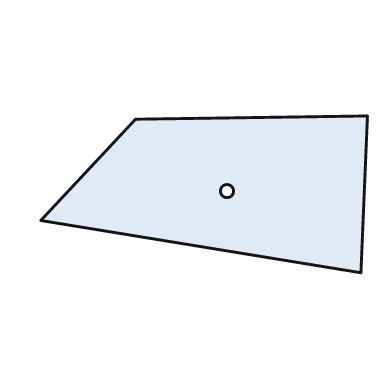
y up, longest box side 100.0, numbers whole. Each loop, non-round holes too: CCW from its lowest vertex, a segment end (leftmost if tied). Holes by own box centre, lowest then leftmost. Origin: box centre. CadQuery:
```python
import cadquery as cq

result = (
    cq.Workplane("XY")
    .moveTo(48.0, -24.0)
    .lineTo(50.0, 24.0)
    .lineTo(-21.0, 23.0)
    .lineTo(-50.0, -8.0)
    .close()
    .moveTo(7.0, 1.0)
    .circle(2.0)
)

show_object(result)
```